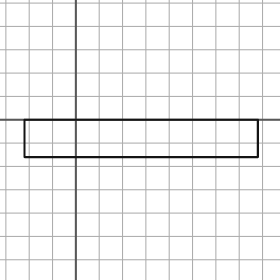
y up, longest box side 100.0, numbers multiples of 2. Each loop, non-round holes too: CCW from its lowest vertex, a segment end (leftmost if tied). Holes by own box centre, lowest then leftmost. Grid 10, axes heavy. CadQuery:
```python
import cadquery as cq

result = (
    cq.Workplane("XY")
    .moveTo(-22.0, -16.0)
    .lineTo(78.0, -16.0)
    .lineTo(78.0, 0.0)
    .lineTo(-22.0, 0.0)
    .close()
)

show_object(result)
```